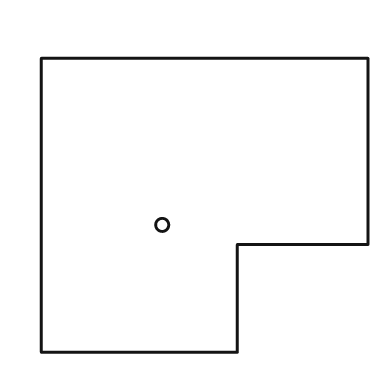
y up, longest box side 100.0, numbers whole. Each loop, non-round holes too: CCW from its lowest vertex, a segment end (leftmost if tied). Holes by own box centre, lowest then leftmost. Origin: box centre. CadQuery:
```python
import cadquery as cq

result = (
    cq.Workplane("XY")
    .moveTo(-50.0, -45.0)
    .lineTo(10.0, -45.0)
    .lineTo(10.0, -12.0)
    .lineTo(50.0, -12.0)
    .lineTo(50.0, 45.0)
    .lineTo(-50.0, 45.0)
    .close()
    .moveTo(-13.0, -6.0)
    .circle(2.0)
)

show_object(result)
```